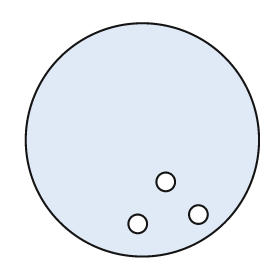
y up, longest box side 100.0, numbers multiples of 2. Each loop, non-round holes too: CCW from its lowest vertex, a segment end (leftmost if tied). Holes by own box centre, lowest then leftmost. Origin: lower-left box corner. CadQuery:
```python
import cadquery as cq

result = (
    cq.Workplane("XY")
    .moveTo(50.0, 50.0)
    .circle(50.0)
    .moveTo(48.0, 14.0)
    .circle(4.0)
    .moveTo(74.0, 18.0)
    .circle(4.0)
    .moveTo(60.0, 32.0)
    .circle(4.0)
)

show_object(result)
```